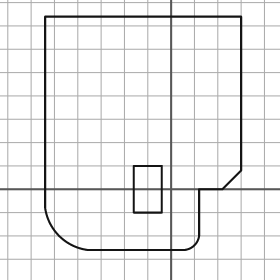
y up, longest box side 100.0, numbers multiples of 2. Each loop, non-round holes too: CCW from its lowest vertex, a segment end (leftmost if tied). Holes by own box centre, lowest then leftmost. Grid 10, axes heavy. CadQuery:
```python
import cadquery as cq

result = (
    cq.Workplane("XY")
    .moveTo(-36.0, -26.0)
    .lineTo(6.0, -26.0)
    .threePointArc((10.0, -24.0), (12.0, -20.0))
    .lineTo(12.0, 0.0)
    .lineTo(22.0, 0.0)
    .lineTo(30.0, 8.0)
    .lineTo(30.0, 74.0)
    .lineTo(-54.0, 74.0)
    .lineTo(-54.0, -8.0)
    .threePointArc((-48.0, -20.0), (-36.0, -26.0))
    .close()
    .moveTo(-16.0, -10.0)
    .lineTo(-4.0, -10.0)
    .lineTo(-4.0, 10.0)
    .lineTo(-16.0, 10.0)
    .close()
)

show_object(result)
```